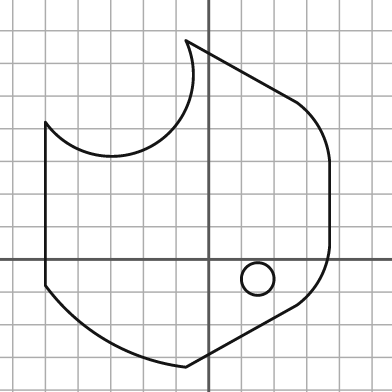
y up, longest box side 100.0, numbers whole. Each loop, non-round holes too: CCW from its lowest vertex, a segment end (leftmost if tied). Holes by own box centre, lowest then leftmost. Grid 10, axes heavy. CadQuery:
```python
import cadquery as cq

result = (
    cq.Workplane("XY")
    .moveTo(-7.0, -33.0)
    .lineTo(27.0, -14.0)
    .threePointArc((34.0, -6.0), (37.0, 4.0))
    .lineTo(37.0, 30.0)
    .threePointArc((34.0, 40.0), (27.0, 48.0))
    .lineTo(-7.0, 67.0)
    .threePointArc((-17.0, 35.0), (-50.0, 42.0))
    .lineTo(-50.0, -8.0)
    .threePointArc((-31.0, -25.0), (-7.0, -33.0))
    .close()
    .moveTo(15.0, -6.0)
    .circle(5.0)
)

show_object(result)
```